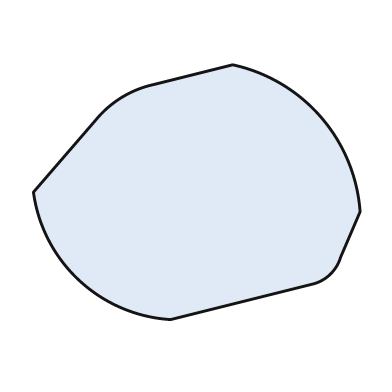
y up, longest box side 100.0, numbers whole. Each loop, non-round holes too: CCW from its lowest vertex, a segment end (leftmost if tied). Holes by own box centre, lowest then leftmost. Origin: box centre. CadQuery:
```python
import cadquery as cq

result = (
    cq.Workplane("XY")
    .moveTo(-8.0, -39.0)
    .lineTo(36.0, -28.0)
    .threePointArc((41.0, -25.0), (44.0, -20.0))
    .lineTo(50.0, -6.0)
    .threePointArc((38.0, 23.0), (11.0, 39.0))
    .lineTo(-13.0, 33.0)
    .threePointArc((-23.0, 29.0), (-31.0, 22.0))
    .lineTo(-50.0, 0.0)
    .threePointArc((-36.0, -27.0), (-8.0, -39.0))
    .close()
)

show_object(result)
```